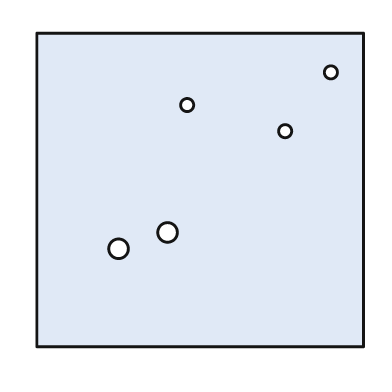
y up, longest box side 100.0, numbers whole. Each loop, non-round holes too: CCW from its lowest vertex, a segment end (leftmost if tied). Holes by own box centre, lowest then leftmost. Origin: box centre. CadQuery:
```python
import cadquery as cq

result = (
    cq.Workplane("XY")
    .moveTo(-50.0, -48.0)
    .lineTo(50.0, -48.0)
    .lineTo(50.0, 48.0)
    .lineTo(-50.0, 48.0)
    .close()
    .moveTo(-25.0, -18.0)
    .circle(3.0)
    .moveTo(-10.0, -13.0)
    .circle(3.0)
    .moveTo(26.0, 18.0)
    .circle(2.0)
    .moveTo(-4.0, 26.0)
    .circle(2.0)
    .moveTo(40.0, 36.0)
    .circle(2.0)
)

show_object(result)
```